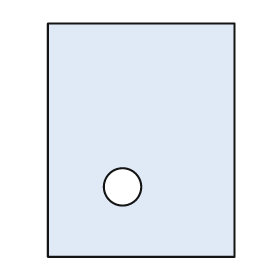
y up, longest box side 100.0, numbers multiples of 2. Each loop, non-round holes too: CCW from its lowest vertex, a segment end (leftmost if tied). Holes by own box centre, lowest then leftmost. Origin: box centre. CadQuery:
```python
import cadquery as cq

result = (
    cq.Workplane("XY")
    .moveTo(-40.0, -50.0)
    .lineTo(40.0, -50.0)
    .lineTo(40.0, 50.0)
    .lineTo(-40.0, 50.0)
    .close()
    .moveTo(-8.0, -20.0)
    .circle(8.0)
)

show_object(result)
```